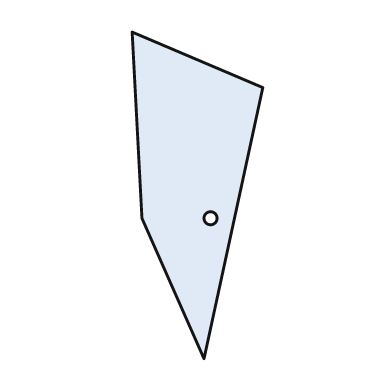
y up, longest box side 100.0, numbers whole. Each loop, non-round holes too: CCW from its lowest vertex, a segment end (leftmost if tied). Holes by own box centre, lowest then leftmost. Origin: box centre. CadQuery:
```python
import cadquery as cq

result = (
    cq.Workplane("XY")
    .moveTo(2.0, -50.0)
    .lineTo(20.0, 33.0)
    .lineTo(-20.0, 50.0)
    .lineTo(-17.0, -7.0)
    .close()
    .moveTo(4.0, -7.0)
    .circle(2.0)
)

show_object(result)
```